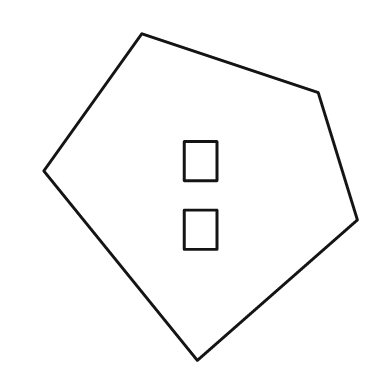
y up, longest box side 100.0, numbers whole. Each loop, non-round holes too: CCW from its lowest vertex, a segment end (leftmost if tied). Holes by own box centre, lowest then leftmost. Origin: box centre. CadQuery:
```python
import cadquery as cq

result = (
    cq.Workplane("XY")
    .moveTo(-1.0, -50.0)
    .lineTo(48.0, -7.0)
    .lineTo(36.0, 32.0)
    .lineTo(-18.0, 50.0)
    .lineTo(-48.0, 8.0)
    .close()
    .moveTo(-5.0, -16.0)
    .lineTo(5.0, -16.0)
    .lineTo(5.0, -4.0)
    .lineTo(-5.0, -4.0)
    .close()
    .moveTo(-5.0, 5.0)
    .lineTo(5.0, 5.0)
    .lineTo(5.0, 17.0)
    .lineTo(-5.0, 17.0)
    .close()
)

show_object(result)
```